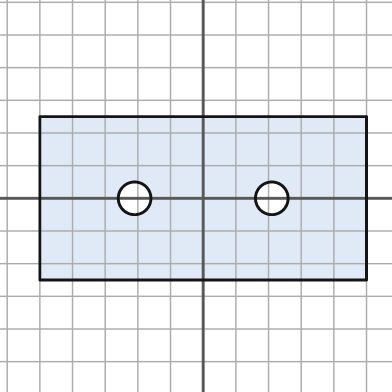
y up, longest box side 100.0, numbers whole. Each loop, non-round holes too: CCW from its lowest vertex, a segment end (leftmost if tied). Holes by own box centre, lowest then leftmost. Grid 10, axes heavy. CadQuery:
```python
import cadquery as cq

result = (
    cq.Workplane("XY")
    .moveTo(-50.0, -25.0)
    .lineTo(50.0, -25.0)
    .lineTo(50.0, 25.0)
    .lineTo(-50.0, 25.0)
    .close()
    .moveTo(-21.0, 0.0)
    .circle(5.0)
    .moveTo(21.0, 0.0)
    .circle(5.0)
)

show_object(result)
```